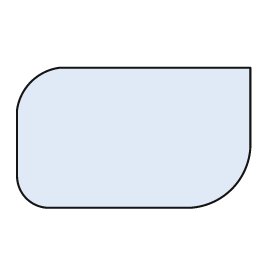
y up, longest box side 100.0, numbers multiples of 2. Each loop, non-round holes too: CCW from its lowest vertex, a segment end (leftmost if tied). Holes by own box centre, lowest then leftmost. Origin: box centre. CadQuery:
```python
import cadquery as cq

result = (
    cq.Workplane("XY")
    .moveTo(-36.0, -30.0)
    .lineTo(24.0, -30.0)
    .threePointArc((42.0, -22.0), (50.0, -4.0))
    .lineTo(50.0, 30.0)
    .lineTo(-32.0, 30.0)
    .threePointArc((-44.0, 24.0), (-50.0, 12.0))
    .lineTo(-50.0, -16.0)
    .threePointArc((-46.0, -26.0), (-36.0, -30.0))
    .close()
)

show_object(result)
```